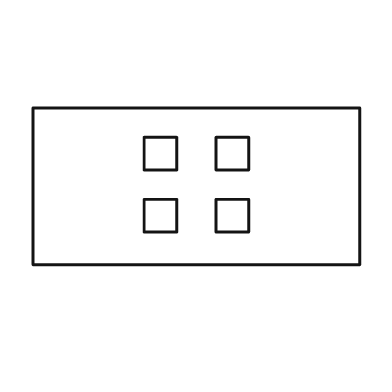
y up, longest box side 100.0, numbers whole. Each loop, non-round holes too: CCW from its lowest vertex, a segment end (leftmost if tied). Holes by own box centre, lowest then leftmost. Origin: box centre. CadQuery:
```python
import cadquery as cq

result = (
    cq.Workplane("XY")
    .moveTo(-50.0, -24.0)
    .lineTo(50.0, -24.0)
    .lineTo(50.0, 24.0)
    .lineTo(-50.0, 24.0)
    .close()
    .moveTo(-16.0, -14.0)
    .lineTo(-6.0, -14.0)
    .lineTo(-6.0, -4.0)
    .lineTo(-16.0, -4.0)
    .close()
    .moveTo(6.0, -14.0)
    .lineTo(16.0, -14.0)
    .lineTo(16.0, -4.0)
    .lineTo(6.0, -4.0)
    .close()
    .moveTo(-16.0, 5.0)
    .lineTo(-6.0, 5.0)
    .lineTo(-6.0, 15.0)
    .lineTo(-16.0, 15.0)
    .close()
    .moveTo(6.0, 5.0)
    .lineTo(16.0, 5.0)
    .lineTo(16.0, 15.0)
    .lineTo(6.0, 15.0)
    .close()
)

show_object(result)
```